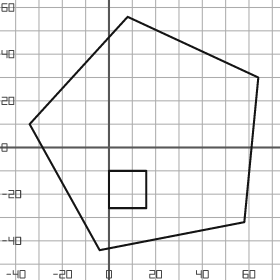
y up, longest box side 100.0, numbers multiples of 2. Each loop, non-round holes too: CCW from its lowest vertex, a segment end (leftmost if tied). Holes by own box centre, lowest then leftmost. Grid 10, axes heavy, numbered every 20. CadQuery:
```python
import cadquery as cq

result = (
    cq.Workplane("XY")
    .moveTo(-4.0, -44.0)
    .lineTo(58.0, -32.0)
    .lineTo(64.0, 30.0)
    .lineTo(8.0, 56.0)
    .lineTo(-34.0, 10.0)
    .close()
    .moveTo(0.0, -26.0)
    .lineTo(16.0, -26.0)
    .lineTo(16.0, -10.0)
    .lineTo(0.0, -10.0)
    .close()
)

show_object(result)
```